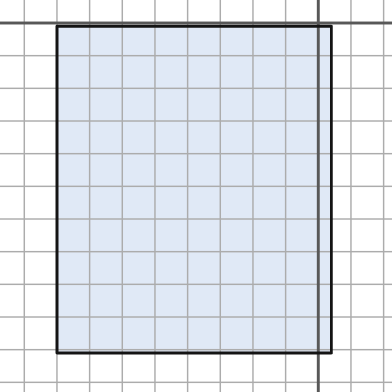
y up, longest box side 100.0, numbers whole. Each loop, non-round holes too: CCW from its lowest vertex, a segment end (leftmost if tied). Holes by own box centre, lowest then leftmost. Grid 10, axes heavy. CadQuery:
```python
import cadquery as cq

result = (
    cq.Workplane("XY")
    .moveTo(-80.0, -101.0)
    .lineTo(4.0, -101.0)
    .lineTo(4.0, -1.0)
    .lineTo(-80.0, -1.0)
    .close()
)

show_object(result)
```